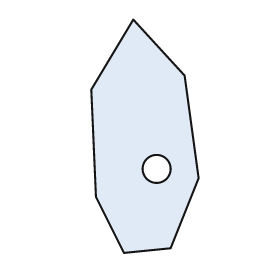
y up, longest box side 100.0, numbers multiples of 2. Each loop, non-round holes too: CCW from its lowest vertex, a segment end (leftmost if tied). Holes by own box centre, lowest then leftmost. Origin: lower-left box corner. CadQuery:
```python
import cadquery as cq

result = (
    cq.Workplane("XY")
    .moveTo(14.0, 0.0)
    .lineTo(34.0, 2.0)
    .lineTo(46.0, 32.0)
    .lineTo(40.0, 76.0)
    .lineTo(18.0, 100.0)
    .lineTo(0.0, 70.0)
    .lineTo(2.0, 24.0)
    .close()
    .moveTo(28.0, 36.0)
    .circle(6.0)
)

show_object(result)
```